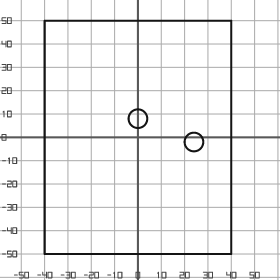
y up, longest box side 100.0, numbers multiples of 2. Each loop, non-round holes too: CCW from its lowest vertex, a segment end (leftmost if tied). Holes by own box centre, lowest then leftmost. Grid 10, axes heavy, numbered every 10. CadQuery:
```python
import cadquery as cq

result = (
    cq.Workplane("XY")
    .moveTo(-40.0, -50.0)
    .lineTo(40.0, -50.0)
    .lineTo(40.0, 50.0)
    .lineTo(-40.0, 50.0)
    .close()
    .moveTo(24.0, -2.0)
    .circle(4.0)
    .moveTo(0.0, 8.0)
    .circle(4.0)
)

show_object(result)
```